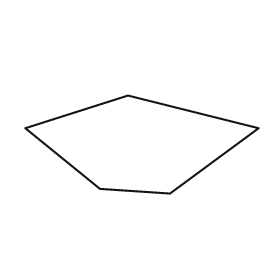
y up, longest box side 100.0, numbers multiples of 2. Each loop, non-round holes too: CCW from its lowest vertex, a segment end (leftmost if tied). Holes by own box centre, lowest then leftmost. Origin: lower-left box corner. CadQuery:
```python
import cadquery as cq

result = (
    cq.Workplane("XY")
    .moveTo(62.0, 0.0)
    .lineTo(100.0, 28.0)
    .lineTo(44.0, 42.0)
    .lineTo(0.0, 28.0)
    .lineTo(32.0, 2.0)
    .close()
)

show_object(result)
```